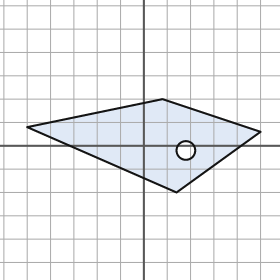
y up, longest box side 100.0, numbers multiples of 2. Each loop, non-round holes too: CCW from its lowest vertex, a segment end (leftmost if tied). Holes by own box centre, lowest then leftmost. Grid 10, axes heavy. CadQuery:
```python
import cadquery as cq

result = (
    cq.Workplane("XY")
    .moveTo(14.0, -20.0)
    .lineTo(50.0, 6.0)
    .lineTo(8.0, 20.0)
    .lineTo(-50.0, 8.0)
    .close()
    .moveTo(18.0, -2.0)
    .circle(4.0)
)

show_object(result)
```